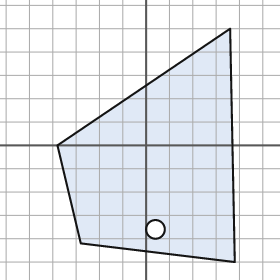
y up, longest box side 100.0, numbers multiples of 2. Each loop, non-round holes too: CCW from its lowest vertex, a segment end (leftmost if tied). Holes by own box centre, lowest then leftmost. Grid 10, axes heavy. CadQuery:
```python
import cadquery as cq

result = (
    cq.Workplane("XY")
    .moveTo(38.0, -50.0)
    .lineTo(36.0, 50.0)
    .lineTo(-38.0, 0.0)
    .lineTo(-28.0, -42.0)
    .close()
    .moveTo(4.0, -36.0)
    .circle(4.0)
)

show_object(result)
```